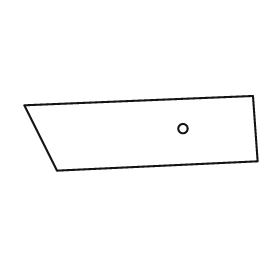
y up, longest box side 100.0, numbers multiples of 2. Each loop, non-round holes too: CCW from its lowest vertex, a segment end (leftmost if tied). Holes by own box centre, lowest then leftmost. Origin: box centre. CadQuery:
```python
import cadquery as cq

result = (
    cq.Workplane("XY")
    .moveTo(-36.0, -16.0)
    .lineTo(50.0, -12.0)
    .lineTo(48.0, 16.0)
    .lineTo(-50.0, 12.0)
    .close()
    .moveTo(18.0, 2.0)
    .circle(2.0)
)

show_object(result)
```